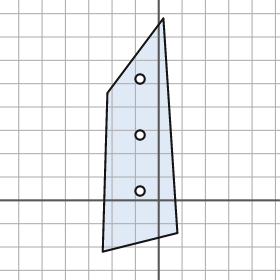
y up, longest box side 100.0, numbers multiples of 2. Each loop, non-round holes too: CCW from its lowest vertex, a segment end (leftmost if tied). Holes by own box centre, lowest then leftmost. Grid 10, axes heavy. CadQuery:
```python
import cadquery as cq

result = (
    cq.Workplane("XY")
    .moveTo(-24.0, -22.0)
    .lineTo(8.0, -14.0)
    .lineTo(2.0, 78.0)
    .lineTo(-22.0, 46.0)
    .close()
    .moveTo(-8.0, 4.0)
    .circle(2.0)
    .moveTo(-8.0, 28.0)
    .circle(2.0)
    .moveTo(-8.0, 52.0)
    .circle(2.0)
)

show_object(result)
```